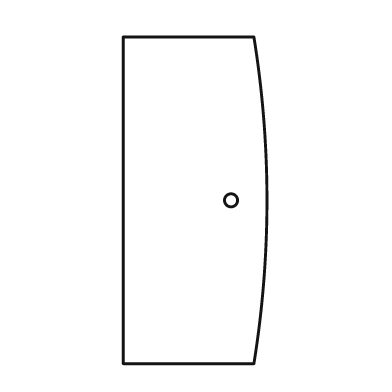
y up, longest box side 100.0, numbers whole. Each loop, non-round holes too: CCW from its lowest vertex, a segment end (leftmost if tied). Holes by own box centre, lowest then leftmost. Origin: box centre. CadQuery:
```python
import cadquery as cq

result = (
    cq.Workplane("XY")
    .moveTo(-22.0, -50.0)
    .lineTo(18.0, -50.0)
    .threePointArc((22.0, 0.0), (18.0, 50.0))
    .lineTo(-22.0, 50.0)
    .close()
    .moveTo(11.0, 0.0)
    .circle(2.0)
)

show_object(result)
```